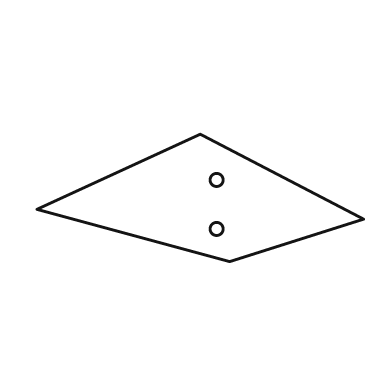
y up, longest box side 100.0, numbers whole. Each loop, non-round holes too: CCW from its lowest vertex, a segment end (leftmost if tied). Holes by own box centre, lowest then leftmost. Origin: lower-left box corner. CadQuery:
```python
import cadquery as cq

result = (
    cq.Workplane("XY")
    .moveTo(59.0, 0.0)
    .lineTo(100.0, 13.0)
    .lineTo(50.0, 39.0)
    .lineTo(0.0, 16.0)
    .close()
    .moveTo(55.0, 10.0)
    .circle(2.0)
    .moveTo(55.0, 25.0)
    .circle(2.0)
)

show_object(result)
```